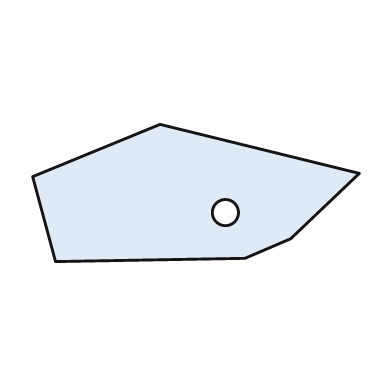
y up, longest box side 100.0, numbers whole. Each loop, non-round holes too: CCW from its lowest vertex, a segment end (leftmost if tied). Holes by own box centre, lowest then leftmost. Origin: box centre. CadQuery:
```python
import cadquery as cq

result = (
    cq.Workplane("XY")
    .moveTo(-43.0, -21.0)
    .lineTo(15.0, -20.0)
    .lineTo(29.0, -14.0)
    .lineTo(50.0, 6.0)
    .lineTo(-11.0, 21.0)
    .lineTo(-50.0, 5.0)
    .close()
    .moveTo(9.0, -6.0)
    .circle(4.0)
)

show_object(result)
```